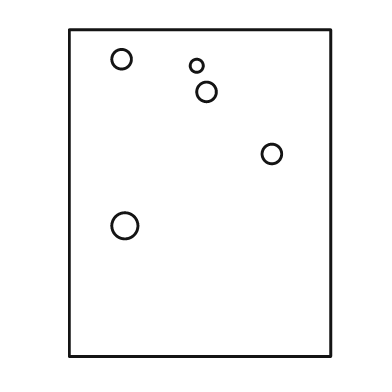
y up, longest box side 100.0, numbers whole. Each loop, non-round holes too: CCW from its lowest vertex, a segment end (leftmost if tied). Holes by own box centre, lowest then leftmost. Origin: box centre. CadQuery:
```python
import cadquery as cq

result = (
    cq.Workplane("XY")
    .moveTo(-40.0, -50.0)
    .lineTo(40.0, -50.0)
    .lineTo(40.0, 50.0)
    .lineTo(-40.0, 50.0)
    .close()
    .moveTo(-23.0, -10.0)
    .circle(4.0)
    .moveTo(22.0, 12.0)
    .circle(3.0)
    .moveTo(2.0, 31.0)
    .circle(3.0)
    .moveTo(-1.0, 39.0)
    .circle(2.0)
    .moveTo(-24.0, 41.0)
    .circle(3.0)
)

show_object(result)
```